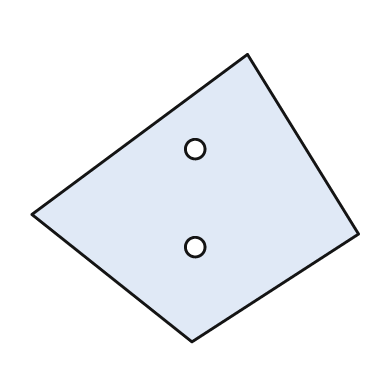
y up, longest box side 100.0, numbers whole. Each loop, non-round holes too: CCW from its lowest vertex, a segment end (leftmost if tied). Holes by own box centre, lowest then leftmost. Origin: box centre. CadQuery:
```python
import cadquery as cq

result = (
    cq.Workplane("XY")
    .moveTo(-1.0, -44.0)
    .lineTo(50.0, -11.0)
    .lineTo(16.0, 44.0)
    .lineTo(-50.0, -5.0)
    .close()
    .moveTo(0.0, -15.0)
    .circle(3.0)
    .moveTo(0.0, 15.0)
    .circle(3.0)
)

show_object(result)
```